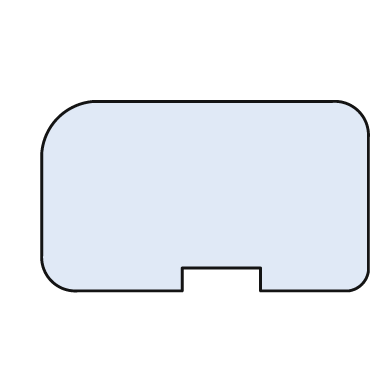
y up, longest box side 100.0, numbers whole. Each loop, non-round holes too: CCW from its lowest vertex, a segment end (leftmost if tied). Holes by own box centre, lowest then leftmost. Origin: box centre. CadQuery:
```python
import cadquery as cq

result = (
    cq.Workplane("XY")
    .moveTo(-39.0, -29.0)
    .lineTo(-7.0, -29.0)
    .lineTo(-7.0, -22.0)
    .lineTo(17.0, -22.0)
    .lineTo(17.0, -29.0)
    .lineTo(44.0, -29.0)
    .threePointArc((48.0, -27.0), (50.0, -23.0))
    .lineTo(50.0, 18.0)
    .threePointArc((47.0, 26.0), (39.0, 29.0))
    .lineTo(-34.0, 29.0)
    .threePointArc((-45.0, 24.0), (-50.0, 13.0))
    .lineTo(-50.0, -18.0)
    .threePointArc((-47.0, -26.0), (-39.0, -29.0))
    .close()
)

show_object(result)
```